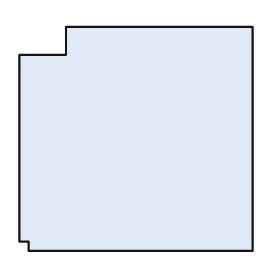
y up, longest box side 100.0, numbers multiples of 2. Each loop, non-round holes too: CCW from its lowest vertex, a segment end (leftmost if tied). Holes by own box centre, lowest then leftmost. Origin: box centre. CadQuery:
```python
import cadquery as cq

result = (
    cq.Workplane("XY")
    .moveTo(-46.0, -48.0)
    .lineTo(50.0, -48.0)
    .lineTo(50.0, 48.0)
    .lineTo(-30.0, 48.0)
    .lineTo(-30.0, 36.0)
    .lineTo(-50.0, 36.0)
    .lineTo(-50.0, -44.0)
    .lineTo(-46.0, -44.0)
    .close()
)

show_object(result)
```